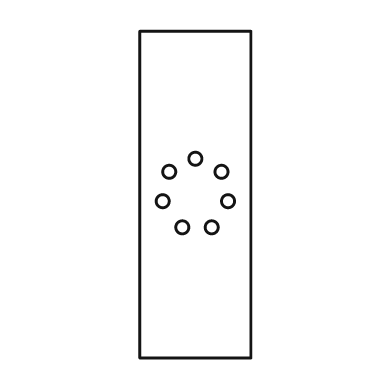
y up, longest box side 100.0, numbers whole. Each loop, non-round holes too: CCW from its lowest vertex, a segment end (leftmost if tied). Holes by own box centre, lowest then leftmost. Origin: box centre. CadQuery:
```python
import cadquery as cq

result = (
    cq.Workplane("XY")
    .moveTo(-17.0, -50.0)
    .lineTo(17.0, -50.0)
    .lineTo(17.0, 50.0)
    .lineTo(-17.0, 50.0)
    .close()
    .moveTo(-4.0, -10.0)
    .circle(2.0)
    .moveTo(5.0, -10.0)
    .circle(2.0)
    .moveTo(-10.0, -2.0)
    .circle(2.0)
    .moveTo(10.0, -2.0)
    .circle(2.0)
    .moveTo(-8.0, 7.0)
    .circle(2.0)
    .moveTo(8.0, 7.0)
    .circle(2.0)
    .moveTo(0.0, 11.0)
    .circle(2.0)
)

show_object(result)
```